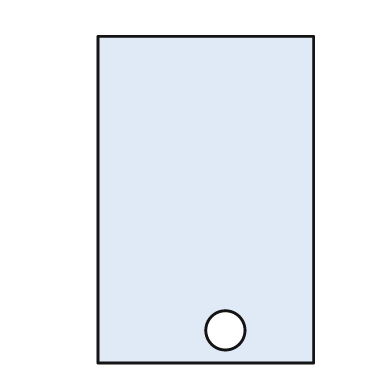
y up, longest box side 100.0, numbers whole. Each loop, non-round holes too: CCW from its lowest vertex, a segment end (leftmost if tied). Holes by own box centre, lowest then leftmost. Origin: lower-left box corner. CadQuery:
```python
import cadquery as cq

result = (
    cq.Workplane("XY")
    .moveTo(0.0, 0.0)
    .lineTo(66.0, 0.0)
    .lineTo(66.0, 100.0)
    .lineTo(0.0, 100.0)
    .close()
    .moveTo(39.0, 10.0)
    .circle(6.0)
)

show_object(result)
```